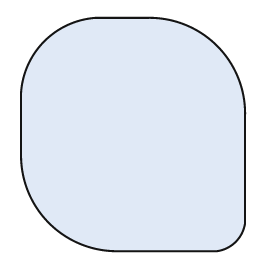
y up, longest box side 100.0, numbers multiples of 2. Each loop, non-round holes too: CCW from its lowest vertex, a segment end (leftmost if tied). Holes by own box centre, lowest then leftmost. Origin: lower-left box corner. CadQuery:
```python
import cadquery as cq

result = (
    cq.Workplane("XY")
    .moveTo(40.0, 0.0)
    .lineTo(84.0, 0.0)
    .threePointArc((92.0, 4.0), (96.0, 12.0))
    .lineTo(96.0, 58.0)
    .threePointArc((84.0, 88.0), (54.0, 100.0))
    .lineTo(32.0, 100.0)
    .threePointArc((10.0, 90.0), (0.0, 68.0))
    .lineTo(0.0, 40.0)
    .threePointArc((12.0, 12.0), (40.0, 0.0))
    .close()
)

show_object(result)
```